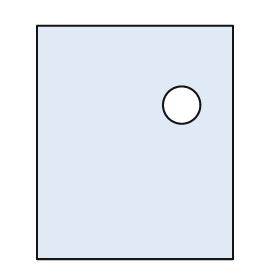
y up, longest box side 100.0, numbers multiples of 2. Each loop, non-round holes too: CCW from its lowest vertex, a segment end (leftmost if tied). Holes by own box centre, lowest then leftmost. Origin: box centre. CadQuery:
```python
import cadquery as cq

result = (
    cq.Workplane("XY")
    .moveTo(-42.0, -50.0)
    .lineTo(42.0, -50.0)
    .lineTo(42.0, 50.0)
    .lineTo(-42.0, 50.0)
    .close()
    .moveTo(20.0, 16.0)
    .circle(8.0)
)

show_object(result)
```